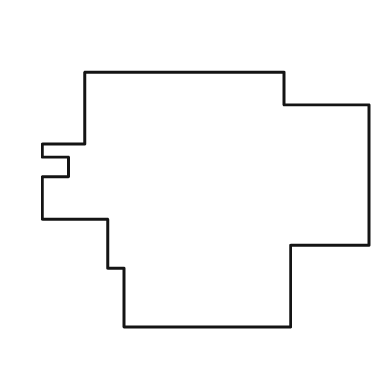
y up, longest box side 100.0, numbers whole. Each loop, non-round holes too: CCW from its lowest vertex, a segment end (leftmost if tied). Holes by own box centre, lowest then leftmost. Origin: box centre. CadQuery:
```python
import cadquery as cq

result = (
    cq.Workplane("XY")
    .moveTo(-25.0, -39.0)
    .lineTo(26.0, -39.0)
    .lineTo(26.0, -14.0)
    .lineTo(50.0, -14.0)
    .lineTo(50.0, 29.0)
    .lineTo(24.0, 29.0)
    .lineTo(24.0, 39.0)
    .lineTo(-37.0, 39.0)
    .lineTo(-37.0, 17.0)
    .lineTo(-50.0, 17.0)
    .lineTo(-50.0, 13.0)
    .lineTo(-42.0, 13.0)
    .lineTo(-42.0, 7.0)
    .lineTo(-50.0, 7.0)
    .lineTo(-50.0, -6.0)
    .lineTo(-30.0, -6.0)
    .lineTo(-30.0, -21.0)
    .lineTo(-25.0, -21.0)
    .close()
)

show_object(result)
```